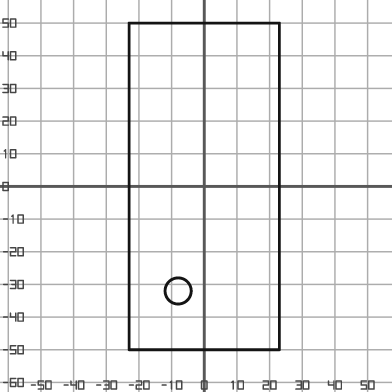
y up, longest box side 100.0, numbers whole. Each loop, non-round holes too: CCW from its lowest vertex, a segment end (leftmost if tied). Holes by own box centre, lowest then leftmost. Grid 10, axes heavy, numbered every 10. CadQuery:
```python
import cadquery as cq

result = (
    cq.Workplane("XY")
    .moveTo(-23.0, -50.0)
    .lineTo(23.0, -50.0)
    .lineTo(23.0, 50.0)
    .lineTo(-23.0, 50.0)
    .close()
    .moveTo(-8.0, -32.0)
    .circle(4.0)
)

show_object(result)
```